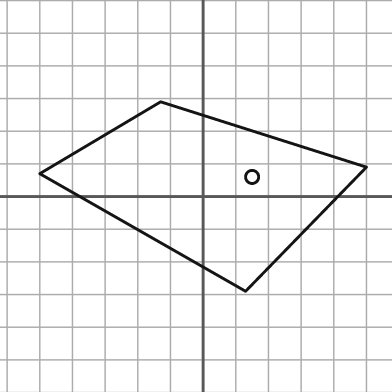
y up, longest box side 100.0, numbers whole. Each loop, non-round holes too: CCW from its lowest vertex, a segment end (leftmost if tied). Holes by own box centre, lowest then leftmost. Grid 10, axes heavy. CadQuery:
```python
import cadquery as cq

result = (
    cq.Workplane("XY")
    .moveTo(13.0, -29.0)
    .lineTo(50.0, 9.0)
    .lineTo(-13.0, 29.0)
    .lineTo(-50.0, 7.0)
    .close()
    .moveTo(15.0, 6.0)
    .circle(2.0)
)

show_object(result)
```